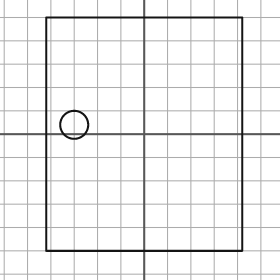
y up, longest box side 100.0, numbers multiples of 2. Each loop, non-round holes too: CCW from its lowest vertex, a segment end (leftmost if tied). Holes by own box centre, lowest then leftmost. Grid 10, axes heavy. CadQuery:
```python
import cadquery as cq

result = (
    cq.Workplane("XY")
    .moveTo(-42.0, -50.0)
    .lineTo(42.0, -50.0)
    .lineTo(42.0, 50.0)
    .lineTo(-42.0, 50.0)
    .close()
    .moveTo(-30.0, 4.0)
    .circle(6.0)
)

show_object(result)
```